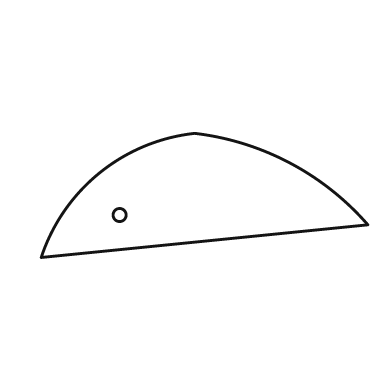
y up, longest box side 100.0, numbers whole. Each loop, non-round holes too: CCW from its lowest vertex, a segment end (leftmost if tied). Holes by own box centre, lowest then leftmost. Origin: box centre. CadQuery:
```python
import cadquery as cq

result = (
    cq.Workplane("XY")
    .moveTo(-50.0, -19.0)
    .lineTo(50.0, -9.0)
    .threePointArc((26.0, 10.0), (-3.0, 19.0))
    .threePointArc((-32.0, 7.0), (-50.0, -19.0))
    .close()
    .moveTo(-26.0, -6.0)
    .circle(2.0)
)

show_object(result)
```